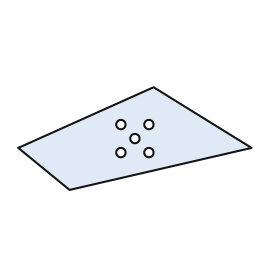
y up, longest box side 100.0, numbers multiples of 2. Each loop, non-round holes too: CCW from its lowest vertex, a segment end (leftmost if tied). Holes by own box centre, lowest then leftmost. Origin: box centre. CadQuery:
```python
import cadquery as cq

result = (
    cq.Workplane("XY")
    .moveTo(-28.0, -22.0)
    .lineTo(50.0, -4.0)
    .lineTo(8.0, 22.0)
    .lineTo(-50.0, -4.0)
    .close()
    .moveTo(-6.0, -6.0)
    .circle(2.0)
    .moveTo(6.0, -6.0)
    .circle(2.0)
    .moveTo(0.0, 0.0)
    .circle(2.0)
    .moveTo(-6.0, 6.0)
    .circle(2.0)
    .moveTo(6.0, 6.0)
    .circle(2.0)
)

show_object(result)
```